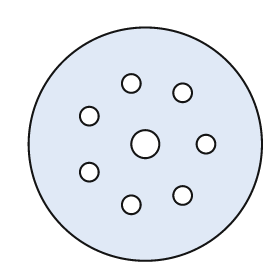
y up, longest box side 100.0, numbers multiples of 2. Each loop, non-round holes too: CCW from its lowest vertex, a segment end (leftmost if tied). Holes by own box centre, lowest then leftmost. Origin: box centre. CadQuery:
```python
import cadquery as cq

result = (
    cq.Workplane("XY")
    .moveTo(0.0, 0.0)
    .circle(50.0)
    .moveTo(-6.0, -26.0)
    .circle(4.0)
    .moveTo(16.0, -22.0)
    .circle(4.0)
    .moveTo(-24.0, -12.0)
    .circle(4.0)
    .moveTo(0.0, 0.0)
    .circle(6.0)
    .moveTo(26.0, 0.0)
    .circle(4.0)
    .moveTo(-24.0, 12.0)
    .circle(4.0)
    .moveTo(16.0, 22.0)
    .circle(4.0)
    .moveTo(-6.0, 26.0)
    .circle(4.0)
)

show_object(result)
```